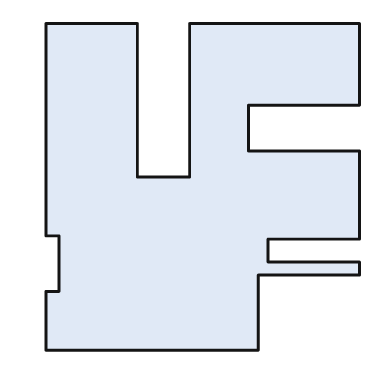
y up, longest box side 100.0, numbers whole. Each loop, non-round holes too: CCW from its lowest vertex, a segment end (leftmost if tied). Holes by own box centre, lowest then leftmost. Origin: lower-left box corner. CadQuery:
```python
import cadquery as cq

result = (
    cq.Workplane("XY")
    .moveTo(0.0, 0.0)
    .lineTo(65.0, 0.0)
    .lineTo(65.0, 23.0)
    .lineTo(96.0, 23.0)
    .lineTo(96.0, 27.0)
    .lineTo(68.0, 27.0)
    .lineTo(68.0, 34.0)
    .lineTo(96.0, 34.0)
    .lineTo(96.0, 61.0)
    .lineTo(62.0, 61.0)
    .lineTo(62.0, 75.0)
    .lineTo(96.0, 75.0)
    .lineTo(96.0, 100.0)
    .lineTo(44.0, 100.0)
    .lineTo(44.0, 53.0)
    .lineTo(28.0, 53.0)
    .lineTo(28.0, 100.0)
    .lineTo(0.0, 100.0)
    .lineTo(0.0, 35.0)
    .lineTo(4.0, 35.0)
    .lineTo(4.0, 18.0)
    .lineTo(0.0, 18.0)
    .close()
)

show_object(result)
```